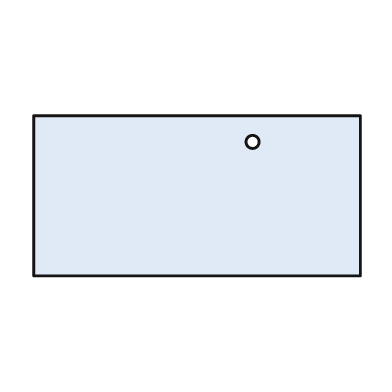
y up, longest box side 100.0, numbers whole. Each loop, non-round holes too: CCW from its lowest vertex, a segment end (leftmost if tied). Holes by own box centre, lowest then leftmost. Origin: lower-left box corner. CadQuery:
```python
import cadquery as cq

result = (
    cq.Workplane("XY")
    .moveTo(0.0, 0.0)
    .lineTo(100.0, 0.0)
    .lineTo(100.0, 49.0)
    .lineTo(0.0, 49.0)
    .close()
    .moveTo(67.0, 41.0)
    .circle(2.0)
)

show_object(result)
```